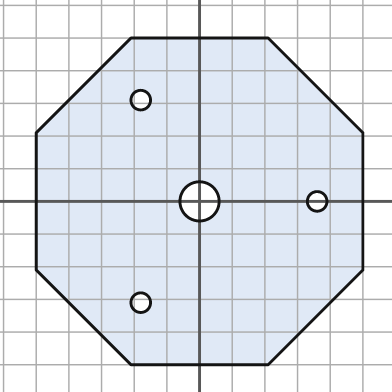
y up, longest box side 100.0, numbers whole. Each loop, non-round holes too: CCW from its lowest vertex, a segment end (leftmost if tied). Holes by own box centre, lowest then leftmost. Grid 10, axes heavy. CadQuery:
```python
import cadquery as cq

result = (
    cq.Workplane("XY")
    .moveTo(-21.0, -50.0)
    .lineTo(21.0, -50.0)
    .lineTo(50.0, -21.0)
    .lineTo(50.0, 21.0)
    .lineTo(21.0, 50.0)
    .lineTo(-21.0, 50.0)
    .lineTo(-50.0, 21.0)
    .lineTo(-50.0, -21.0)
    .close()
    .moveTo(-18.0, -31.0)
    .circle(3.0)
    .moveTo(0.0, 0.0)
    .circle(6.0)
    .moveTo(36.0, 0.0)
    .circle(3.0)
    .moveTo(-18.0, 31.0)
    .circle(3.0)
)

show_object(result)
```